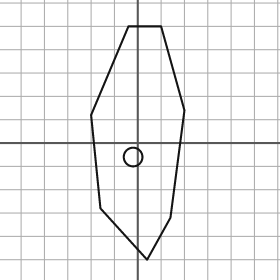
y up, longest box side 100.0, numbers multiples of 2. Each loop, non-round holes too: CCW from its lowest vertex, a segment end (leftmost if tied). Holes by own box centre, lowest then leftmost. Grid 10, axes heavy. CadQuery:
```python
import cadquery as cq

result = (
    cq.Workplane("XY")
    .moveTo(4.0, -50.0)
    .lineTo(14.0, -32.0)
    .lineTo(20.0, 14.0)
    .lineTo(10.0, 50.0)
    .lineTo(-4.0, 50.0)
    .lineTo(-20.0, 12.0)
    .lineTo(-16.0, -28.0)
    .close()
    .moveTo(-2.0, -6.0)
    .circle(4.0)
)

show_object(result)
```